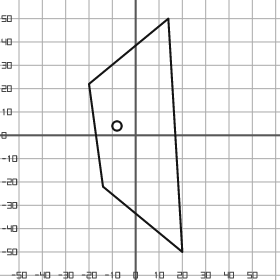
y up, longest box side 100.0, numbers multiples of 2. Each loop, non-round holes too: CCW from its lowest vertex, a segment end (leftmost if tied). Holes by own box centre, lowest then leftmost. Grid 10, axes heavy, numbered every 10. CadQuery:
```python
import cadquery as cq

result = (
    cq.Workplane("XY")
    .moveTo(20.0, -50.0)
    .lineTo(14.0, 50.0)
    .lineTo(-20.0, 22.0)
    .lineTo(-14.0, -22.0)
    .close()
    .moveTo(-8.0, 4.0)
    .circle(2.0)
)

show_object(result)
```